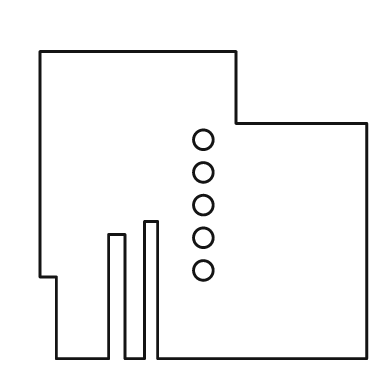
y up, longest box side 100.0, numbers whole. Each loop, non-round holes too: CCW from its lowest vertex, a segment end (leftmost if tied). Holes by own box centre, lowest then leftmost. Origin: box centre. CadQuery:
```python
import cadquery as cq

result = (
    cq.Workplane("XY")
    .moveTo(-45.0, -47.0)
    .lineTo(-29.0, -47.0)
    .lineTo(-29.0, -9.0)
    .lineTo(-24.0, -9.0)
    .lineTo(-24.0, -47.0)
    .lineTo(-18.0, -47.0)
    .lineTo(-18.0, -5.0)
    .lineTo(-14.0, -5.0)
    .lineTo(-14.0, -47.0)
    .lineTo(50.0, -47.0)
    .lineTo(50.0, 25.0)
    .lineTo(10.0, 25.0)
    .lineTo(10.0, 47.0)
    .lineTo(-50.0, 47.0)
    .lineTo(-50.0, -22.0)
    .lineTo(-45.0, -22.0)
    .close()
    .moveTo(0.0, -20.0)
    .circle(3.0)
    .moveTo(0.0, -10.0)
    .circle(3.0)
    .moveTo(0.0, 0.0)
    .circle(3.0)
    .moveTo(0.0, 10.0)
    .circle(3.0)
    .moveTo(0.0, 20.0)
    .circle(3.0)
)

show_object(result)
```